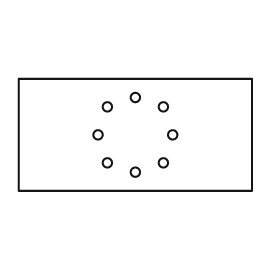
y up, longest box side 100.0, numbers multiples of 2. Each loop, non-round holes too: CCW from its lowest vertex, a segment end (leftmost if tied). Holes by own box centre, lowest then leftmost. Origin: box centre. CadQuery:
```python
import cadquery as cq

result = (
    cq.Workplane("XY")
    .moveTo(-50.0, -24.0)
    .lineTo(50.0, -24.0)
    .lineTo(50.0, 24.0)
    .lineTo(-50.0, 24.0)
    .close()
    .moveTo(0.0, -16.0)
    .circle(2.0)
    .moveTo(-12.0, -12.0)
    .circle(2.0)
    .moveTo(12.0, -12.0)
    .circle(2.0)
    .moveTo(-16.0, 0.0)
    .circle(2.0)
    .moveTo(16.0, 0.0)
    .circle(2.0)
    .moveTo(-12.0, 12.0)
    .circle(2.0)
    .moveTo(12.0, 12.0)
    .circle(2.0)
    .moveTo(0.0, 16.0)
    .circle(2.0)
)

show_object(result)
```